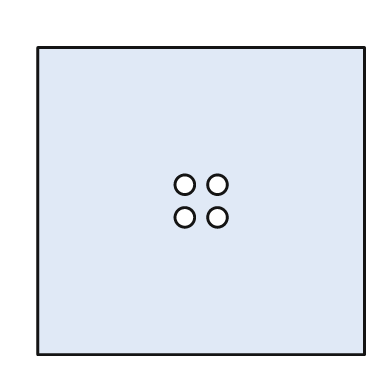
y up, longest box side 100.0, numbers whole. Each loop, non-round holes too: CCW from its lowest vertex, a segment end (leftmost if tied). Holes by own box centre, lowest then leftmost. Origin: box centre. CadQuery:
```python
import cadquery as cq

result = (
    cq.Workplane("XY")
    .moveTo(-50.0, -47.0)
    .lineTo(50.0, -47.0)
    .lineTo(50.0, 47.0)
    .lineTo(-50.0, 47.0)
    .close()
    .moveTo(-5.0, -5.0)
    .circle(3.0)
    .moveTo(5.0, -5.0)
    .circle(3.0)
    .moveTo(-5.0, 5.0)
    .circle(3.0)
    .moveTo(5.0, 5.0)
    .circle(3.0)
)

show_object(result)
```